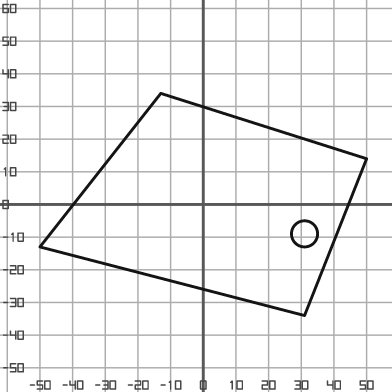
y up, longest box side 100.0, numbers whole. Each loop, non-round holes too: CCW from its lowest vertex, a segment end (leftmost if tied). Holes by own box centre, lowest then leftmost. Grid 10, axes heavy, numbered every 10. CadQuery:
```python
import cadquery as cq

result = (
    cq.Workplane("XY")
    .moveTo(31.0, -34.0)
    .lineTo(50.0, 14.0)
    .lineTo(-13.0, 34.0)
    .lineTo(-50.0, -13.0)
    .close()
    .moveTo(31.0, -9.0)
    .circle(4.0)
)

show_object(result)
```